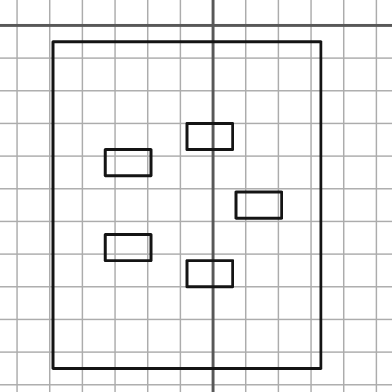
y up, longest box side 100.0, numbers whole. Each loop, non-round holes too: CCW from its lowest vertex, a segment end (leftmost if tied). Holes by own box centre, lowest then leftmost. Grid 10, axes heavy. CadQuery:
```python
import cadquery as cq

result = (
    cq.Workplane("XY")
    .moveTo(-49.0, -105.0)
    .lineTo(33.0, -105.0)
    .lineTo(33.0, -5.0)
    .lineTo(-49.0, -5.0)
    .close()
    .moveTo(-8.0, -80.0)
    .lineTo(6.0, -80.0)
    .lineTo(6.0, -72.0)
    .lineTo(-8.0, -72.0)
    .close()
    .moveTo(-33.0, -72.0)
    .lineTo(-19.0, -72.0)
    .lineTo(-19.0, -64.0)
    .lineTo(-33.0, -64.0)
    .close()
    .moveTo(7.0, -59.0)
    .lineTo(21.0, -59.0)
    .lineTo(21.0, -51.0)
    .lineTo(7.0, -51.0)
    .close()
    .moveTo(-33.0, -46.0)
    .lineTo(-19.0, -46.0)
    .lineTo(-19.0, -38.0)
    .lineTo(-33.0, -38.0)
    .close()
    .moveTo(-8.0, -38.0)
    .lineTo(6.0, -38.0)
    .lineTo(6.0, -30.0)
    .lineTo(-8.0, -30.0)
    .close()
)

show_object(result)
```